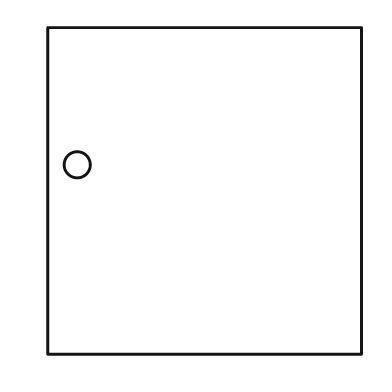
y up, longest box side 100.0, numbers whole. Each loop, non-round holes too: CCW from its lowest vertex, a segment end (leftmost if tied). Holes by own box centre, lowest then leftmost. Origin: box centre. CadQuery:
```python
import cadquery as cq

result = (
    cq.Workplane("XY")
    .moveTo(-48.0, -50.0)
    .lineTo(48.0, -50.0)
    .lineTo(48.0, 50.0)
    .lineTo(-48.0, 50.0)
    .close()
    .moveTo(-39.0, 8.0)
    .circle(4.0)
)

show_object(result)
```